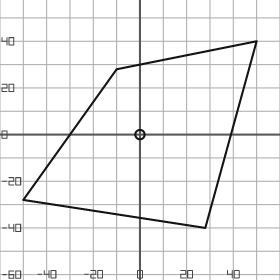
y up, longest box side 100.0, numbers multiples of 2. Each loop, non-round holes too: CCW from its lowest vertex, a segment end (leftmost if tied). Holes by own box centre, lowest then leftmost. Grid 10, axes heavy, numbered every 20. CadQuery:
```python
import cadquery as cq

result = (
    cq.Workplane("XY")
    .moveTo(28.0, -40.0)
    .lineTo(50.0, 40.0)
    .lineTo(-10.0, 28.0)
    .lineTo(-50.0, -28.0)
    .close()
    .moveTo(0.0, 0.0)
    .circle(2.0)
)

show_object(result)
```